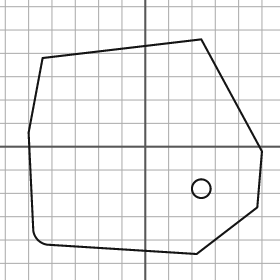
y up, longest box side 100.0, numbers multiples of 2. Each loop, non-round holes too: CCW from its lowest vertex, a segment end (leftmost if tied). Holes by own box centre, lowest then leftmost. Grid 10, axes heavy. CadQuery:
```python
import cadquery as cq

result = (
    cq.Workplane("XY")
    .moveTo(22.0, -46.0)
    .lineTo(48.0, -26.0)
    .lineTo(50.0, -2.0)
    .lineTo(24.0, 46.0)
    .lineTo(-44.0, 38.0)
    .lineTo(-50.0, 6.0)
    .lineTo(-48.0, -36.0)
    .threePointArc((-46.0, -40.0), (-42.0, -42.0))
    .close()
    .moveTo(24.0, -18.0)
    .circle(4.0)
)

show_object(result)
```